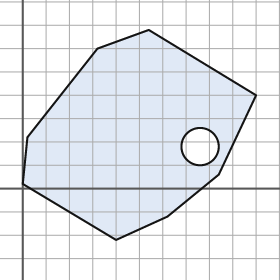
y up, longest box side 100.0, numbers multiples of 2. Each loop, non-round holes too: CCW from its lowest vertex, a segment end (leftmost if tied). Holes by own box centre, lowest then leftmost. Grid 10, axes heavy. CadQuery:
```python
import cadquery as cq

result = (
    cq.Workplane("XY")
    .moveTo(40.0, -22.0)
    .lineTo(62.0, -12.0)
    .lineTo(84.0, 6.0)
    .lineTo(100.0, 40.0)
    .lineTo(54.0, 68.0)
    .lineTo(32.0, 60.0)
    .lineTo(2.0, 22.0)
    .lineTo(0.0, 2.0)
    .close()
    .moveTo(76.0, 18.0)
    .circle(8.0)
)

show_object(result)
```